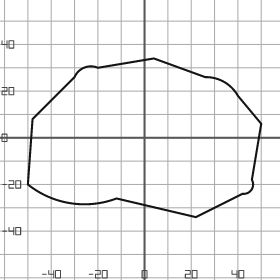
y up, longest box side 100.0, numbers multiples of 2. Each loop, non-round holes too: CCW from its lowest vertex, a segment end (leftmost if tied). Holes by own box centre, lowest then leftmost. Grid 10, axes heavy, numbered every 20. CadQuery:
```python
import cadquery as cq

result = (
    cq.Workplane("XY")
    .moveTo(22.0, -34.0)
    .lineTo(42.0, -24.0)
    .threePointArc((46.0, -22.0), (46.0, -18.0))
    .lineTo(50.0, 6.0)
    .lineTo(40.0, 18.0)
    .threePointArc((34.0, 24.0), (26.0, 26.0))
    .lineTo(4.0, 34.0)
    .lineTo(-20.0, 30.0)
    .threePointArc((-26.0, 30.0), (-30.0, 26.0))
    .lineTo(-48.0, 8.0)
    .lineTo(-50.0, -20.0)
    .threePointArc((-32.0, -28.0), (-12.0, -26.0))
    .close()
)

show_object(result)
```